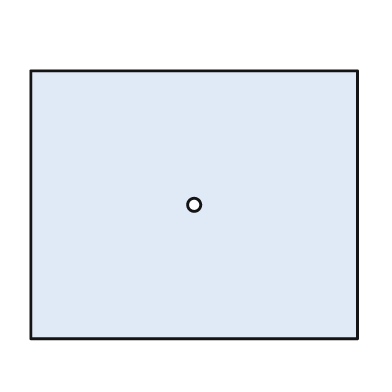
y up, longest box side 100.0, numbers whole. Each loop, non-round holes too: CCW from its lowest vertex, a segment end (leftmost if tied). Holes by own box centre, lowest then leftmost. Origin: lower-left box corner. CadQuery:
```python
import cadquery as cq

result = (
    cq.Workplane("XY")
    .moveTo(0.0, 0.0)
    .lineTo(100.0, 0.0)
    .lineTo(100.0, 82.0)
    .lineTo(0.0, 82.0)
    .close()
    .moveTo(50.0, 41.0)
    .circle(2.0)
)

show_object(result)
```